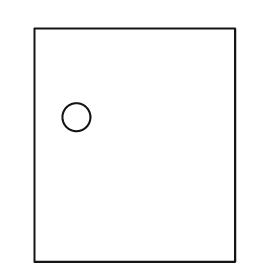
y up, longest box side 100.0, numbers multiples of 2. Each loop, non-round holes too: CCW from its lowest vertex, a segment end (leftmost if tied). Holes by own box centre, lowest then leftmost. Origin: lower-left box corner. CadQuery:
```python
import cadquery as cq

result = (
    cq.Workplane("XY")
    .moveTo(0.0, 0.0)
    .lineTo(86.0, 0.0)
    .lineTo(86.0, 100.0)
    .lineTo(0.0, 100.0)
    .close()
    .moveTo(18.0, 62.0)
    .circle(6.0)
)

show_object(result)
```